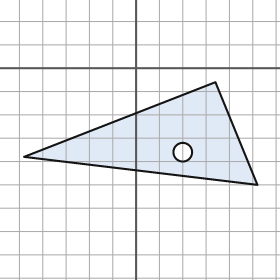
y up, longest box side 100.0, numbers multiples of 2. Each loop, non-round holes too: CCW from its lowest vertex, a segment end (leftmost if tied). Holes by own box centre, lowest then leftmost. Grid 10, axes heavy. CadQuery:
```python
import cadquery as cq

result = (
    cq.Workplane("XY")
    .moveTo(52.0, -50.0)
    .lineTo(34.0, -6.0)
    .lineTo(-48.0, -38.0)
    .close()
    .moveTo(20.0, -36.0)
    .circle(4.0)
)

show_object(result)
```